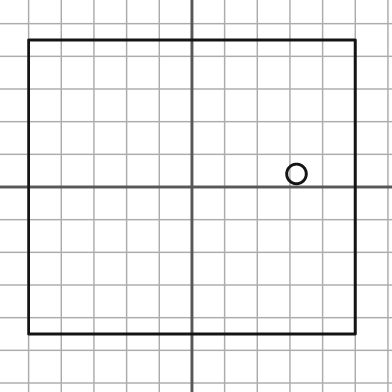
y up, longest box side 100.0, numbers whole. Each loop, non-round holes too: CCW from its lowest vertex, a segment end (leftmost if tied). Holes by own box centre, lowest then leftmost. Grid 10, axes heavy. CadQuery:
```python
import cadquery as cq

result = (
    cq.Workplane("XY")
    .moveTo(-50.0, -45.0)
    .lineTo(50.0, -45.0)
    .lineTo(50.0, 45.0)
    .lineTo(-50.0, 45.0)
    .close()
    .moveTo(32.0, 4.0)
    .circle(3.0)
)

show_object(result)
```